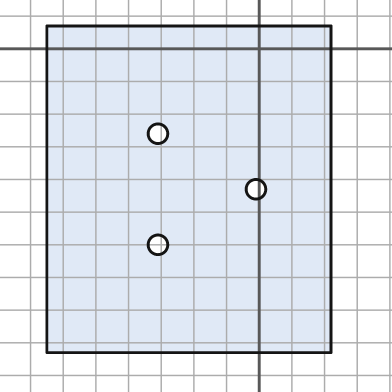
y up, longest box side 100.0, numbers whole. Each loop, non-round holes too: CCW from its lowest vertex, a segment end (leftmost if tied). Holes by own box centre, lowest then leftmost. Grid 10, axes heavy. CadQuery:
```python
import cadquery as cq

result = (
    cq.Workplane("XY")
    .moveTo(-65.0, -93.0)
    .lineTo(22.0, -93.0)
    .lineTo(22.0, 7.0)
    .lineTo(-65.0, 7.0)
    .close()
    .moveTo(-31.0, -60.0)
    .circle(3.0)
    .moveTo(-1.0, -43.0)
    .circle(3.0)
    .moveTo(-31.0, -26.0)
    .circle(3.0)
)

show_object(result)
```